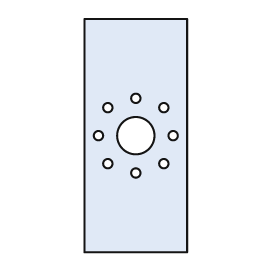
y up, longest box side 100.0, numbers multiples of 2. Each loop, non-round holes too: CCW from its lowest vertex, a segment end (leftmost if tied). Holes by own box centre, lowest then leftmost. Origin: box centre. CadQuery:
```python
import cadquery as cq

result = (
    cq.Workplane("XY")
    .moveTo(-22.0, -50.0)
    .lineTo(22.0, -50.0)
    .lineTo(22.0, 50.0)
    .lineTo(-22.0, 50.0)
    .close()
    .moveTo(0.0, -16.0)
    .circle(2.0)
    .moveTo(-12.0, -12.0)
    .circle(2.0)
    .moveTo(12.0, -12.0)
    .circle(2.0)
    .moveTo(-16.0, 0.0)
    .circle(2.0)
    .moveTo(0.0, 0.0)
    .circle(8.0)
    .moveTo(16.0, 0.0)
    .circle(2.0)
    .moveTo(-12.0, 12.0)
    .circle(2.0)
    .moveTo(12.0, 12.0)
    .circle(2.0)
    .moveTo(0.0, 16.0)
    .circle(2.0)
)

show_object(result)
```